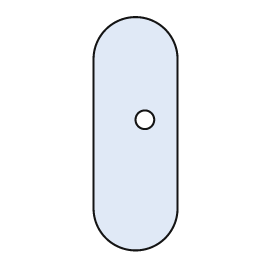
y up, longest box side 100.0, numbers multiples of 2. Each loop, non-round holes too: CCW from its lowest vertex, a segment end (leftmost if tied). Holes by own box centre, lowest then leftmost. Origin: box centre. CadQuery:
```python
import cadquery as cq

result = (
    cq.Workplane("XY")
    .moveTo(-18.0, -32.0)
    .threePointArc((0.0, -50.0), (18.0, -32.0))
    .lineTo(18.0, 32.0)
    .threePointArc((0.0, 50.0), (-18.0, 32.0))
    .close()
    .moveTo(4.0, 6.0)
    .circle(4.0)
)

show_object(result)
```